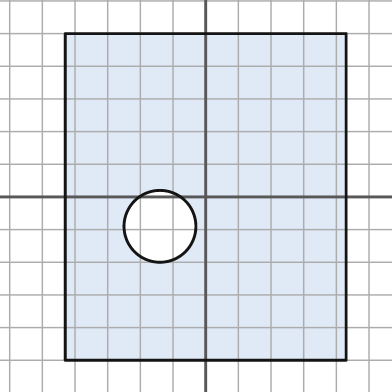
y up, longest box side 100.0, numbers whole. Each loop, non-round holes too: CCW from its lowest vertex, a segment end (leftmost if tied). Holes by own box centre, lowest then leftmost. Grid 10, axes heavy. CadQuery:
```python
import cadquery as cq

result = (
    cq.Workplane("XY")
    .moveTo(-43.0, -50.0)
    .lineTo(43.0, -50.0)
    .lineTo(43.0, 50.0)
    .lineTo(-43.0, 50.0)
    .close()
    .moveTo(-14.0, -9.0)
    .circle(11.0)
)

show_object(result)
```